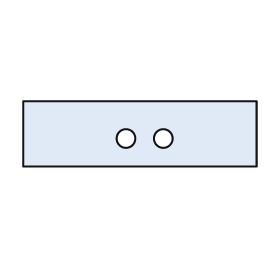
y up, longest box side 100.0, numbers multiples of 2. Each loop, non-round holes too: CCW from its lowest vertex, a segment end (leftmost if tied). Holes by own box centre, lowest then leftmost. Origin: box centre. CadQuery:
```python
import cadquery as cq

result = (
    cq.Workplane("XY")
    .moveTo(-50.0, -14.0)
    .lineTo(50.0, -14.0)
    .lineTo(50.0, 14.0)
    .lineTo(-50.0, 14.0)
    .close()
    .moveTo(-6.0, -2.0)
    .circle(4.0)
    .moveTo(10.0, -2.0)
    .circle(4.0)
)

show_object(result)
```